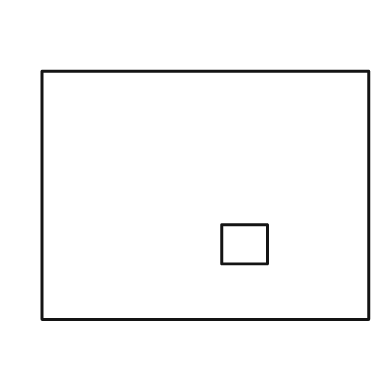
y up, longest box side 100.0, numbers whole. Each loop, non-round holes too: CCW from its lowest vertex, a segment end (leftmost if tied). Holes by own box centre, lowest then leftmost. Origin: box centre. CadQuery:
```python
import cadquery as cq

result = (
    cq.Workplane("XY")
    .moveTo(-50.0, -38.0)
    .lineTo(50.0, -38.0)
    .lineTo(50.0, 38.0)
    .lineTo(-50.0, 38.0)
    .close()
    .moveTo(5.0, -21.0)
    .lineTo(19.0, -21.0)
    .lineTo(19.0, -9.0)
    .lineTo(5.0, -9.0)
    .close()
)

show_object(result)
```